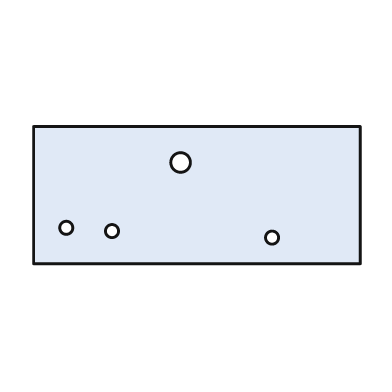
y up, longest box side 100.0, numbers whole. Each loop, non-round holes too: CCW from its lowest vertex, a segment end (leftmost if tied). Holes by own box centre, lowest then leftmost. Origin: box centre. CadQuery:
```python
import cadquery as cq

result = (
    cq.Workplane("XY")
    .moveTo(-50.0, -21.0)
    .lineTo(50.0, -21.0)
    .lineTo(50.0, 21.0)
    .lineTo(-50.0, 21.0)
    .close()
    .moveTo(23.0, -13.0)
    .circle(2.0)
    .moveTo(-26.0, -11.0)
    .circle(2.0)
    .moveTo(-40.0, -10.0)
    .circle(2.0)
    .moveTo(-5.0, 10.0)
    .circle(3.0)
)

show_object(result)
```